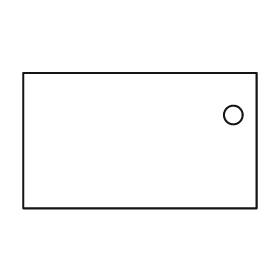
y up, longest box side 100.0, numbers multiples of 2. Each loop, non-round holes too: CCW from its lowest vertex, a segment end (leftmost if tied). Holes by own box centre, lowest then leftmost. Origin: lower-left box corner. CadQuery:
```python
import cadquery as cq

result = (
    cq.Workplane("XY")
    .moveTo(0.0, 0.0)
    .lineTo(100.0, 0.0)
    .lineTo(100.0, 58.0)
    .lineTo(0.0, 58.0)
    .close()
    .moveTo(90.0, 40.0)
    .circle(4.0)
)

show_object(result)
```